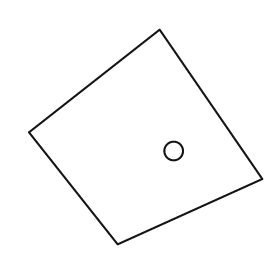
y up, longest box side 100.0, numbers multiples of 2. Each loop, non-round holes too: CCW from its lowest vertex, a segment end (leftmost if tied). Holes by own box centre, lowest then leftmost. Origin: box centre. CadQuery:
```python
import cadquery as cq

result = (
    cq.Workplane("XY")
    .moveTo(-12.0, -46.0)
    .lineTo(50.0, -18.0)
    .lineTo(6.0, 46.0)
    .lineTo(-50.0, 2.0)
    .close()
    .moveTo(12.0, -6.0)
    .circle(4.0)
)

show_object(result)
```